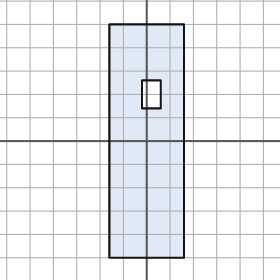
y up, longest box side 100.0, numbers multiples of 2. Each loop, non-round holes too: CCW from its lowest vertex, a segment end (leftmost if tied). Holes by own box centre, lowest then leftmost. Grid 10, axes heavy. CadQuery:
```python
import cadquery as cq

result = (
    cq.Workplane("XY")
    .moveTo(-16.0, -50.0)
    .lineTo(16.0, -50.0)
    .lineTo(16.0, 50.0)
    .lineTo(-16.0, 50.0)
    .close()
    .moveTo(-2.0, 14.0)
    .lineTo(6.0, 14.0)
    .lineTo(6.0, 26.0)
    .lineTo(-2.0, 26.0)
    .close()
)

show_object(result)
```